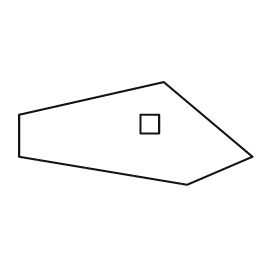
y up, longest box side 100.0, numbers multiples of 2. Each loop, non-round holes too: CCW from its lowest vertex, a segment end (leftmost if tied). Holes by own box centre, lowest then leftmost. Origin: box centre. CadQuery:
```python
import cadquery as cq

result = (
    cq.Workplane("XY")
    .moveTo(22.0, -22.0)
    .lineTo(50.0, -10.0)
    .lineTo(12.0, 22.0)
    .lineTo(-50.0, 8.0)
    .lineTo(-50.0, -10.0)
    .close()
    .moveTo(2.0, 0.0)
    .lineTo(10.0, 0.0)
    .lineTo(10.0, 8.0)
    .lineTo(2.0, 8.0)
    .close()
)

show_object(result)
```